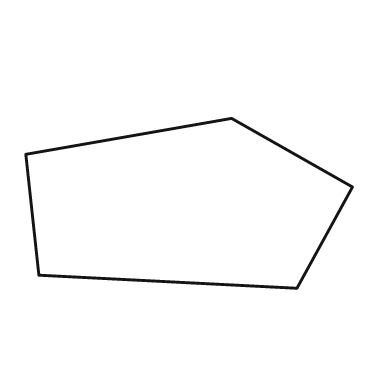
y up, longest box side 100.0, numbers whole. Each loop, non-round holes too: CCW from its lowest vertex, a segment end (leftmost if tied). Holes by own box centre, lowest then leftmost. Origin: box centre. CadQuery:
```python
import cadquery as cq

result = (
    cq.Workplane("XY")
    .moveTo(33.0, -26.0)
    .lineTo(50.0, 5.0)
    .lineTo(13.0, 26.0)
    .lineTo(-50.0, 15.0)
    .lineTo(-46.0, -22.0)
    .close()
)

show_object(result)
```